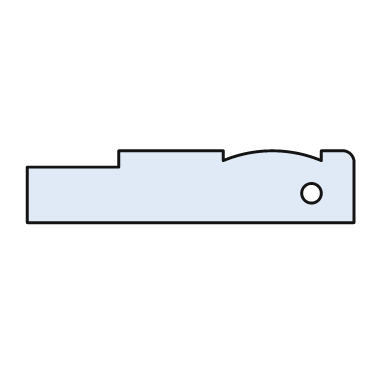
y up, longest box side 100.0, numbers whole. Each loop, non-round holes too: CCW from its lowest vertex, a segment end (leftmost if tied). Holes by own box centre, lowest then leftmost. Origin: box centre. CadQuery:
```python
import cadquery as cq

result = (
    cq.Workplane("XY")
    .moveTo(-50.0, -11.0)
    .lineTo(50.0, -11.0)
    .lineTo(50.0, 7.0)
    .threePointArc((49.0, 10.0), (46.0, 11.0))
    .lineTo(40.0, 11.0)
    .lineTo(40.0, 8.0)
    .threePointArc((25.0, 11.0), (10.0, 8.0))
    .lineTo(10.0, 11.0)
    .lineTo(-22.0, 11.0)
    .lineTo(-22.0, 6.0)
    .lineTo(-50.0, 6.0)
    .close()
    .moveTo(37.0, -2.0)
    .circle(3.0)
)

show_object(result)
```